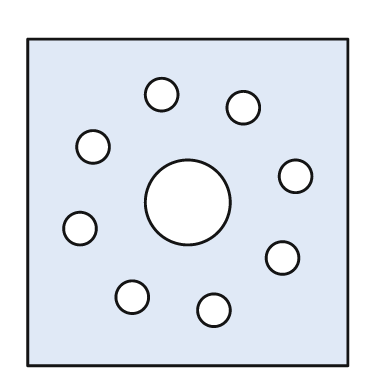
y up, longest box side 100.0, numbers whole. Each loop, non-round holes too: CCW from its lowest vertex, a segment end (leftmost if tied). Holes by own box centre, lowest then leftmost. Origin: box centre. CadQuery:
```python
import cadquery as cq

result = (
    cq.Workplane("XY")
    .moveTo(-49.0, -50.0)
    .lineTo(49.0, -50.0)
    .lineTo(49.0, 50.0)
    .lineTo(-49.0, 50.0)
    .close()
    .moveTo(8.0, -33.0)
    .circle(5.0)
    .moveTo(-17.0, -29.0)
    .circle(5.0)
    .moveTo(29.0, -17.0)
    .circle(5.0)
    .moveTo(-33.0, -8.0)
    .circle(5.0)
    .moveTo(0.0, 0.0)
    .circle(13.0)
    .moveTo(33.0, 8.0)
    .circle(5.0)
    .moveTo(-29.0, 17.0)
    .circle(5.0)
    .moveTo(17.0, 29.0)
    .circle(5.0)
    .moveTo(-8.0, 33.0)
    .circle(5.0)
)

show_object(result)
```